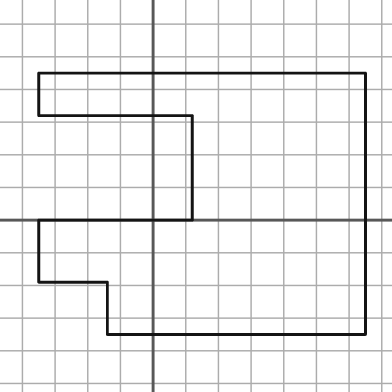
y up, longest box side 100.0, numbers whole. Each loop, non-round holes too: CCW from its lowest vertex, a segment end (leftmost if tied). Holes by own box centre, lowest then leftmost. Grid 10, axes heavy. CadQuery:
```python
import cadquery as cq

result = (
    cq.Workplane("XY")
    .moveTo(-14.0, -35.0)
    .lineTo(65.0, -35.0)
    .lineTo(65.0, 45.0)
    .lineTo(-35.0, 45.0)
    .lineTo(-35.0, 32.0)
    .lineTo(12.0, 32.0)
    .lineTo(12.0, 0.0)
    .lineTo(-35.0, 0.0)
    .lineTo(-35.0, -19.0)
    .lineTo(-14.0, -19.0)
    .close()
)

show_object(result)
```